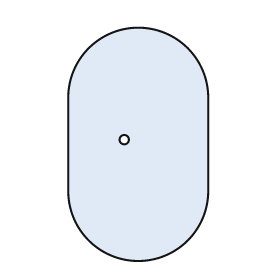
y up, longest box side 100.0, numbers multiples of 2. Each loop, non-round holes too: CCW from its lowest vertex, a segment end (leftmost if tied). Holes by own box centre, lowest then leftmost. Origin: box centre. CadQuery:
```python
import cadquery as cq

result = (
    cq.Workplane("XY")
    .moveTo(-30.0, -20.0)
    .threePointArc((0.0, -50.0), (30.0, -20.0))
    .lineTo(30.0, 20.0)
    .threePointArc((0.0, 50.0), (-30.0, 20.0))
    .close()
    .moveTo(-6.0, 2.0)
    .circle(2.0)
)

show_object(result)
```